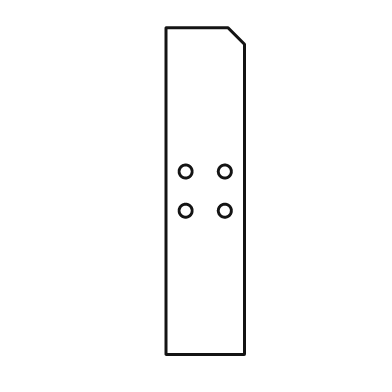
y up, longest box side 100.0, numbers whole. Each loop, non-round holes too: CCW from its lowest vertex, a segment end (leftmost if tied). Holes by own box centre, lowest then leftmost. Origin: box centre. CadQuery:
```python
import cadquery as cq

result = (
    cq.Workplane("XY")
    .moveTo(-12.0, -50.0)
    .lineTo(12.0, -50.0)
    .lineTo(12.0, 45.0)
    .lineTo(7.0, 50.0)
    .lineTo(-12.0, 50.0)
    .close()
    .moveTo(-6.0, -6.0)
    .circle(2.0)
    .moveTo(6.0, -6.0)
    .circle(2.0)
    .moveTo(-6.0, 6.0)
    .circle(2.0)
    .moveTo(6.0, 6.0)
    .circle(2.0)
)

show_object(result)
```